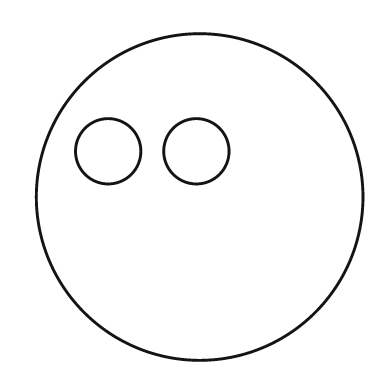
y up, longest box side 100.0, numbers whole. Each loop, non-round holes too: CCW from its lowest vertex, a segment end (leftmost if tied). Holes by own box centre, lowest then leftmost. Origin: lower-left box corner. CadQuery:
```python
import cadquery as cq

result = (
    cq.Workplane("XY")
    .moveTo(50.0, 50.0)
    .circle(50.0)
    .moveTo(22.0, 64.0)
    .circle(10.0)
    .moveTo(49.0, 64.0)
    .circle(10.0)
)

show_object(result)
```